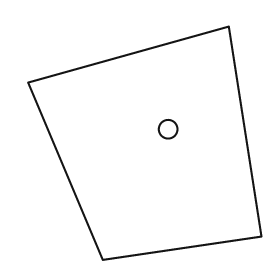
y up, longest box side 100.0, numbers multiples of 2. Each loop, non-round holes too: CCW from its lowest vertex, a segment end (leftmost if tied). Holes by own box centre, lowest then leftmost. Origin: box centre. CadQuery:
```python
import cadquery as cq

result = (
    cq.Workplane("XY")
    .moveTo(-18.0, -50.0)
    .lineTo(50.0, -40.0)
    .lineTo(36.0, 50.0)
    .lineTo(-50.0, 26.0)
    .close()
    .moveTo(10.0, 6.0)
    .circle(4.0)
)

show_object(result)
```